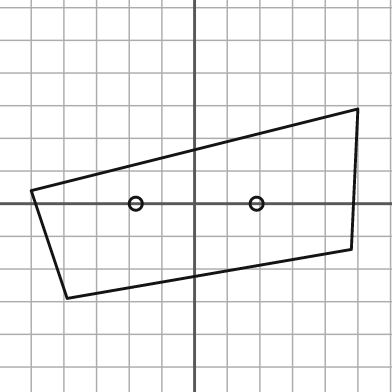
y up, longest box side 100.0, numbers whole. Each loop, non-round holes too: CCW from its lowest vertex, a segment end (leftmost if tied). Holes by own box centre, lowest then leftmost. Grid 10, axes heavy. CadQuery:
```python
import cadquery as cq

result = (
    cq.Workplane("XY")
    .moveTo(-39.0, -29.0)
    .lineTo(48.0, -14.0)
    .lineTo(50.0, 29.0)
    .lineTo(-50.0, 4.0)
    .close()
    .moveTo(-18.0, 0.0)
    .circle(2.0)
    .moveTo(19.0, 0.0)
    .circle(2.0)
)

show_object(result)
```